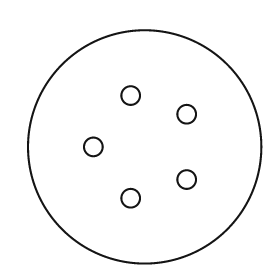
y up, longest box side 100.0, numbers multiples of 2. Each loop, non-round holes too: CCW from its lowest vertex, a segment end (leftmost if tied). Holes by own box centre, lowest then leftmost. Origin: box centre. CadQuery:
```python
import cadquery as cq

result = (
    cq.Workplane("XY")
    .moveTo(0.0, 0.0)
    .circle(50.0)
    .moveTo(-6.0, -22.0)
    .circle(4.0)
    .moveTo(18.0, -14.0)
    .circle(4.0)
    .moveTo(-22.0, 0.0)
    .circle(4.0)
    .moveTo(18.0, 14.0)
    .circle(4.0)
    .moveTo(-6.0, 22.0)
    .circle(4.0)
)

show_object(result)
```